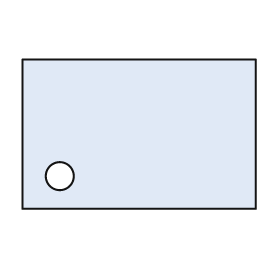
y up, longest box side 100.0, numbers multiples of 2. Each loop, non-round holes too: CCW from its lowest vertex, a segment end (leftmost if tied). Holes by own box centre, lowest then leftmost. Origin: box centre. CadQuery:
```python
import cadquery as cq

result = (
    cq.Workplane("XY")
    .moveTo(-50.0, -32.0)
    .lineTo(50.0, -32.0)
    .lineTo(50.0, 32.0)
    .lineTo(-50.0, 32.0)
    .close()
    .moveTo(-34.0, -18.0)
    .circle(6.0)
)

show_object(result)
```